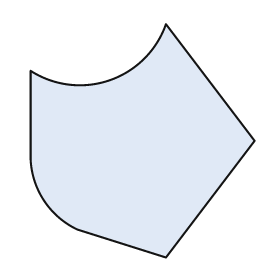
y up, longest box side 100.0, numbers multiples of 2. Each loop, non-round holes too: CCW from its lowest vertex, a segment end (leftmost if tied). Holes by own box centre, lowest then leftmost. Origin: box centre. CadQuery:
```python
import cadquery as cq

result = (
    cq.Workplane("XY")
    .moveTo(10.0, -50.0)
    .lineTo(48.0, 0.0)
    .lineTo(10.0, 50.0)
    .threePointArc((-14.0, 26.0), (-48.0, 30.0))
    .lineTo(-48.0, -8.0)
    .threePointArc((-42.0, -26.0), (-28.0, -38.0))
    .close()
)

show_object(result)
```